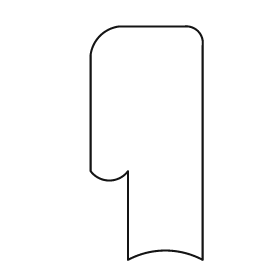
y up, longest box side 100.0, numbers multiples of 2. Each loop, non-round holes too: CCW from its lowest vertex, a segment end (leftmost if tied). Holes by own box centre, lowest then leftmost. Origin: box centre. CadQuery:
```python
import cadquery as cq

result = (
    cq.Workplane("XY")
    .moveTo(-8.0, -50.0)
    .threePointArc((8.0, -46.0), (24.0, -50.0))
    .lineTo(24.0, 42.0)
    .threePointArc((22.0, 48.0), (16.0, 50.0))
    .lineTo(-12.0, 50.0)
    .threePointArc((-20.0, 46.0), (-24.0, 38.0))
    .lineTo(-24.0, -12.0)
    .threePointArc((-16.0, -16.0), (-8.0, -12.0))
    .close()
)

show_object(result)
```